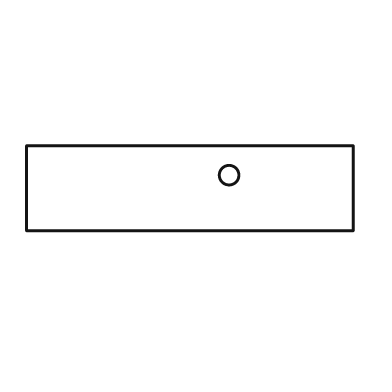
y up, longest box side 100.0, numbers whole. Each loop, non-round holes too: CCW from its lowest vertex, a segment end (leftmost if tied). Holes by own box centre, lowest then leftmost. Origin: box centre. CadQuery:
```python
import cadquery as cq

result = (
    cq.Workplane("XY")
    .moveTo(-50.0, -13.0)
    .lineTo(50.0, -13.0)
    .lineTo(50.0, 13.0)
    .lineTo(-50.0, 13.0)
    .close()
    .moveTo(12.0, 4.0)
    .circle(3.0)
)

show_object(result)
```